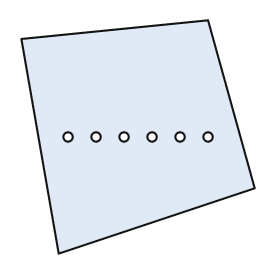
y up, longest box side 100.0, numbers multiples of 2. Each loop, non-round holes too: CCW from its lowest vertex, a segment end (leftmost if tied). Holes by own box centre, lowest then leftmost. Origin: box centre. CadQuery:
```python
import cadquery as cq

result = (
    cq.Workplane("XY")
    .moveTo(-34.0, -50.0)
    .lineTo(50.0, -22.0)
    .lineTo(30.0, 50.0)
    .lineTo(-50.0, 42.0)
    .close()
    .moveTo(-30.0, 0.0)
    .circle(2.0)
    .moveTo(-18.0, 0.0)
    .circle(2.0)
    .moveTo(-6.0, 0.0)
    .circle(2.0)
    .moveTo(6.0, 0.0)
    .circle(2.0)
    .moveTo(18.0, 0.0)
    .circle(2.0)
    .moveTo(30.0, 0.0)
    .circle(2.0)
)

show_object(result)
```